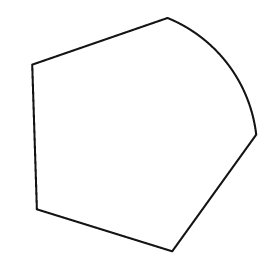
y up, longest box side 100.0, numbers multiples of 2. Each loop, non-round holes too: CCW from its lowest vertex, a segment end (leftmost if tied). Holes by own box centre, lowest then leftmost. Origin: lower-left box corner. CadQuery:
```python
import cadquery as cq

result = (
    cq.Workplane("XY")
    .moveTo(60.0, 0.0)
    .lineTo(96.0, 50.0)
    .threePointArc((84.0, 80.0), (58.0, 100.0))
    .lineTo(0.0, 80.0)
    .lineTo(2.0, 18.0)
    .close()
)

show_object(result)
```